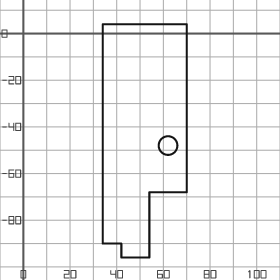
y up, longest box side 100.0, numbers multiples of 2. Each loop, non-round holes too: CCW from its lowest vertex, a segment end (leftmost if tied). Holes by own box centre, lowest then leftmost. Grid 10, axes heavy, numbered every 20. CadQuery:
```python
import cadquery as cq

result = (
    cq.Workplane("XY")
    .moveTo(42.0, -96.0)
    .lineTo(54.0, -96.0)
    .lineTo(54.0, -68.0)
    .lineTo(70.0, -68.0)
    .lineTo(70.0, 4.0)
    .lineTo(34.0, 4.0)
    .lineTo(34.0, -90.0)
    .lineTo(42.0, -90.0)
    .close()
    .moveTo(62.0, -48.0)
    .circle(4.0)
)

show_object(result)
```